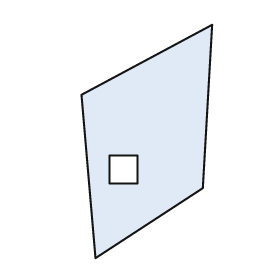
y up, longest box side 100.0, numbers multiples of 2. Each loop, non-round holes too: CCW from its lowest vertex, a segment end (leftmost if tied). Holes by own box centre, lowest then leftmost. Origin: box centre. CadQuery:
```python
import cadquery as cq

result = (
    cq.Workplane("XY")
    .moveTo(-22.0, -50.0)
    .lineTo(24.0, -20.0)
    .lineTo(28.0, 50.0)
    .lineTo(-28.0, 20.0)
    .close()
    .moveTo(-16.0, -18.0)
    .lineTo(-4.0, -18.0)
    .lineTo(-4.0, -6.0)
    .lineTo(-16.0, -6.0)
    .close()
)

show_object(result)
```